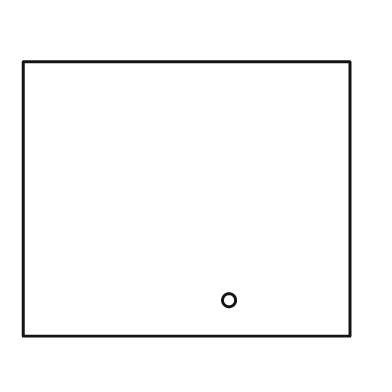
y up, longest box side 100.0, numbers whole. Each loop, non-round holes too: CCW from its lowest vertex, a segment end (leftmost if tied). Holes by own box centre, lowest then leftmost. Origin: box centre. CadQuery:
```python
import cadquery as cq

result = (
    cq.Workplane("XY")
    .moveTo(-50.0, -42.0)
    .lineTo(50.0, -42.0)
    .lineTo(50.0, 42.0)
    .lineTo(-50.0, 42.0)
    .close()
    .moveTo(13.0, -31.0)
    .circle(2.0)
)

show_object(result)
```